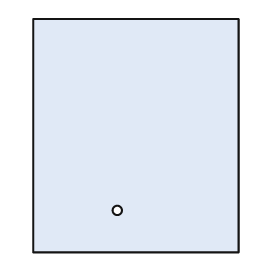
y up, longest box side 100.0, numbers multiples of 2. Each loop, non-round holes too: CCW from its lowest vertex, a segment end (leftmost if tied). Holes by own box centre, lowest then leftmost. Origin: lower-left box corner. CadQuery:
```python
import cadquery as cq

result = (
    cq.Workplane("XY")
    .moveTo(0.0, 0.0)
    .lineTo(88.0, 0.0)
    .lineTo(88.0, 100.0)
    .lineTo(0.0, 100.0)
    .close()
    .moveTo(36.0, 18.0)
    .circle(2.0)
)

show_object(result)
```